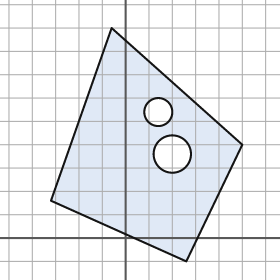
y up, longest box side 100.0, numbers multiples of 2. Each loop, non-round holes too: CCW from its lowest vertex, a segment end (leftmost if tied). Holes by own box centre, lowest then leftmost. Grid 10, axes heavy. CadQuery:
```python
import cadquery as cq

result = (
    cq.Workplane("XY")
    .moveTo(26.0, -10.0)
    .lineTo(50.0, 40.0)
    .lineTo(-6.0, 90.0)
    .lineTo(-32.0, 16.0)
    .close()
    .moveTo(20.0, 36.0)
    .circle(8.0)
    .moveTo(14.0, 54.0)
    .circle(6.0)
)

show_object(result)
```